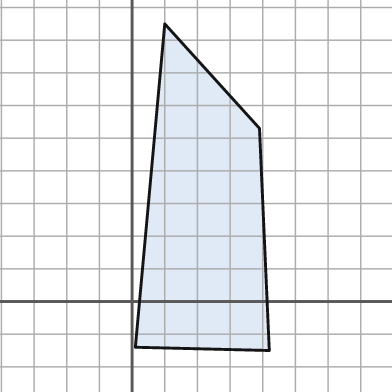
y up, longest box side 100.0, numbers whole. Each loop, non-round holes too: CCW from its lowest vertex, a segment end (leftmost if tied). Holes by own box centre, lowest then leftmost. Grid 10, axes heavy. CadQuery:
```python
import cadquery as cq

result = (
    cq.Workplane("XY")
    .moveTo(42.0, -15.0)
    .lineTo(39.0, 53.0)
    .lineTo(10.0, 85.0)
    .lineTo(1.0, -14.0)
    .close()
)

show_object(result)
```